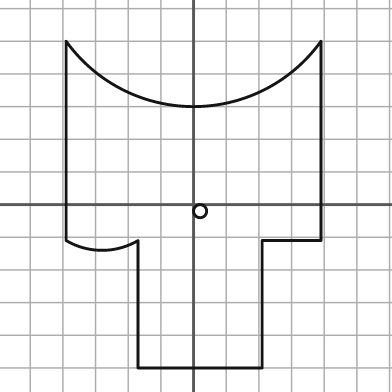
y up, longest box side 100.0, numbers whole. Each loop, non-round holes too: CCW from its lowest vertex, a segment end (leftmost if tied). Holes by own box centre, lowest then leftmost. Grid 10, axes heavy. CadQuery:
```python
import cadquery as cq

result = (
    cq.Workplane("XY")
    .moveTo(-17.0, -50.0)
    .lineTo(21.0, -50.0)
    .lineTo(21.0, -11.0)
    .lineTo(39.0, -11.0)
    .lineTo(39.0, 50.0)
    .threePointArc((0.0, 30.0), (-39.0, 50.0))
    .lineTo(-39.0, -11.0)
    .threePointArc((-28.0, -14.0), (-17.0, -11.0))
    .close()
    .moveTo(2.0, -2.0)
    .circle(2.0)
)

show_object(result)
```